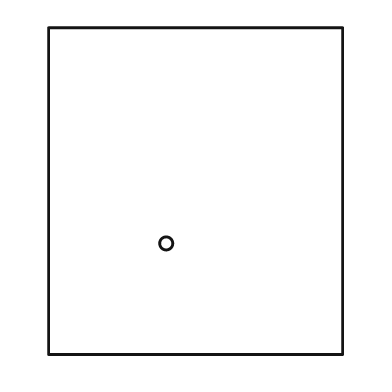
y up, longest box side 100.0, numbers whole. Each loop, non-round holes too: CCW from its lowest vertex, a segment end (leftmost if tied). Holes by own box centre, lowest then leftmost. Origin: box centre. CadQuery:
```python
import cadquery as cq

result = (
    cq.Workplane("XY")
    .moveTo(-45.0, -50.0)
    .lineTo(45.0, -50.0)
    .lineTo(45.0, 50.0)
    .lineTo(-45.0, 50.0)
    .close()
    .moveTo(-9.0, -16.0)
    .circle(2.0)
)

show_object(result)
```